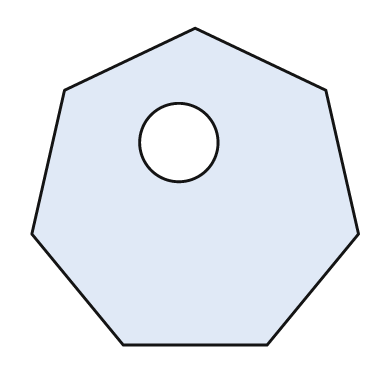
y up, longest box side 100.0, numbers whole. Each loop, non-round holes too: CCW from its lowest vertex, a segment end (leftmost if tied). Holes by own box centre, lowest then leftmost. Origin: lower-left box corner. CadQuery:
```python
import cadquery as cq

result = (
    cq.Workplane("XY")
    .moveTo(28.0, 0.0)
    .lineTo(72.0, 0.0)
    .lineTo(100.0, 34.0)
    .lineTo(90.0, 78.0)
    .lineTo(50.0, 97.0)
    .lineTo(10.0, 78.0)
    .lineTo(0.0, 34.0)
    .close()
    .moveTo(45.0, 62.0)
    .circle(12.0)
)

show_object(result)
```